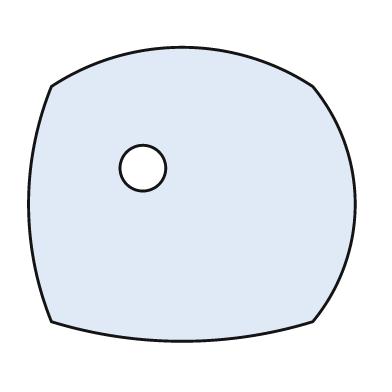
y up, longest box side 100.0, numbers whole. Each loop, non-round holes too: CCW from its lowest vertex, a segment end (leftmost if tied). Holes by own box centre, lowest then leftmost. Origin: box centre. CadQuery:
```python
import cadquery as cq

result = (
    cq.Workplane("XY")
    .moveTo(-43.0, -39.0)
    .threePointArc((-3.0, -45.0), (37.0, -39.0))
    .threePointArc((50.0, -3.0), (37.0, 33.0))
    .threePointArc((-3.0, 45.0), (-43.0, 33.0))
    .threePointArc((-50.0, -3.0), (-43.0, -39.0))
    .close()
    .moveTo(-15.0, 8.0)
    .circle(7.0)
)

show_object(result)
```